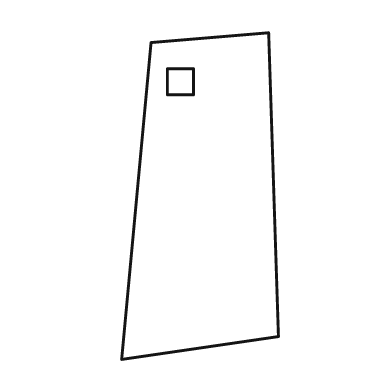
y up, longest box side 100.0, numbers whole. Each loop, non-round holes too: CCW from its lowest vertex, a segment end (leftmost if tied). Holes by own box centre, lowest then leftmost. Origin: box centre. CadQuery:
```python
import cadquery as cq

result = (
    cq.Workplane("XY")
    .moveTo(-24.0, -50.0)
    .lineTo(24.0, -43.0)
    .lineTo(21.0, 50.0)
    .lineTo(-15.0, 47.0)
    .close()
    .moveTo(-10.0, 31.0)
    .lineTo(-2.0, 31.0)
    .lineTo(-2.0, 39.0)
    .lineTo(-10.0, 39.0)
    .close()
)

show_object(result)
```